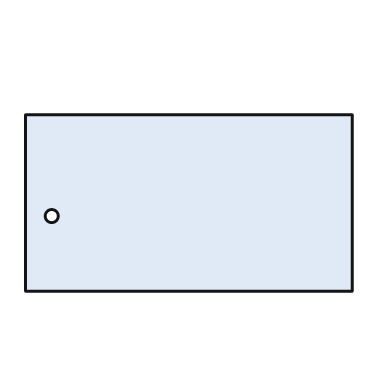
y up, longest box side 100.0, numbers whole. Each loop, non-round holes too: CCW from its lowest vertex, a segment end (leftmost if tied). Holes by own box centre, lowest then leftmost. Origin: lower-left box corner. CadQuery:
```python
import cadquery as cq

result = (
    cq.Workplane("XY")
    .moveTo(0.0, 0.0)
    .lineTo(100.0, 0.0)
    .lineTo(100.0, 54.0)
    .lineTo(0.0, 54.0)
    .close()
    .moveTo(8.0, 23.0)
    .circle(2.0)
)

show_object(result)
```